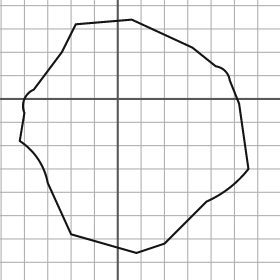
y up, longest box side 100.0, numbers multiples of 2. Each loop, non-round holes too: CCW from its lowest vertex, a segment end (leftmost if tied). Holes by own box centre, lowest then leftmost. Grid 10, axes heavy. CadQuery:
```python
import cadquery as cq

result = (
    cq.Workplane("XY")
    .moveTo(8.0, -66.0)
    .lineTo(20.0, -62.0)
    .lineTo(38.0, -44.0)
    .threePointArc((48.0, -38.0), (56.0, -30.0))
    .lineTo(52.0, -2.0)
    .lineTo(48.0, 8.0)
    .threePointArc((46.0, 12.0), (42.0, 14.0))
    .lineTo(32.0, 22.0)
    .lineTo(6.0, 34.0)
    .lineTo(-18.0, 32.0)
    .lineTo(-24.0, 20.0)
    .lineTo(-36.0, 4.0)
    .threePointArc((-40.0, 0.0), (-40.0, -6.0))
    .lineTo(-42.0, -18.0)
    .threePointArc((-34.0, -26.0), (-30.0, -36.0))
    .lineTo(-20.0, -58.0)
    .close()
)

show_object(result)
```